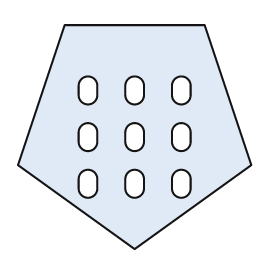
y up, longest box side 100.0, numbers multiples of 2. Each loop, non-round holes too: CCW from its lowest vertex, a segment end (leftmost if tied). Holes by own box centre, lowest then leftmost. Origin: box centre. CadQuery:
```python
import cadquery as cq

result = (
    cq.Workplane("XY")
    .moveTo(0.0, -48.0)
    .lineTo(50.0, -12.0)
    .lineTo(30.0, 48.0)
    .lineTo(-30.0, 48.0)
    .lineTo(-50.0, -12.0)
    .close()
    .moveTo(-24.0, -22.0)
    .threePointArc((-20.0, -26.0), (-16.0, -22.0))
    .lineTo(-16.0, -18.0)
    .threePointArc((-20.0, -14.0), (-24.0, -18.0))
    .close()
    .moveTo(-4.0, -22.0)
    .threePointArc((0.0, -26.0), (4.0, -22.0))
    .lineTo(4.0, -18.0)
    .threePointArc((0.0, -14.0), (-4.0, -18.0))
    .close()
    .moveTo(16.0, -22.0)
    .threePointArc((20.0, -26.0), (24.0, -22.0))
    .lineTo(24.0, -18.0)
    .threePointArc((20.0, -14.0), (16.0, -18.0))
    .close()
    .moveTo(-24.0, -2.0)
    .threePointArc((-20.0, -6.0), (-16.0, -2.0))
    .lineTo(-16.0, 2.0)
    .threePointArc((-20.0, 6.0), (-24.0, 2.0))
    .close()
    .moveTo(-4.0, -2.0)
    .threePointArc((0.0, -6.0), (4.0, -2.0))
    .lineTo(4.0, 2.0)
    .threePointArc((0.0, 6.0), (-4.0, 2.0))
    .close()
    .moveTo(16.0, -2.0)
    .threePointArc((20.0, -6.0), (24.0, -2.0))
    .lineTo(24.0, 2.0)
    .threePointArc((20.0, 6.0), (16.0, 2.0))
    .close()
    .moveTo(-24.0, 18.0)
    .threePointArc((-20.0, 14.0), (-16.0, 18.0))
    .lineTo(-16.0, 22.0)
    .threePointArc((-20.0, 26.0), (-24.0, 22.0))
    .close()
    .moveTo(-4.0, 18.0)
    .threePointArc((0.0, 14.0), (4.0, 18.0))
    .lineTo(4.0, 22.0)
    .threePointArc((0.0, 26.0), (-4.0, 22.0))
    .close()
    .moveTo(16.0, 18.0)
    .threePointArc((20.0, 14.0), (24.0, 18.0))
    .lineTo(24.0, 22.0)
    .threePointArc((20.0, 26.0), (16.0, 22.0))
    .close()
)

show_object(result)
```